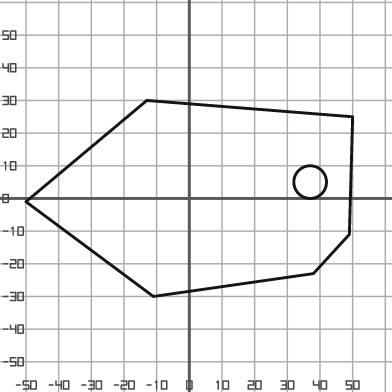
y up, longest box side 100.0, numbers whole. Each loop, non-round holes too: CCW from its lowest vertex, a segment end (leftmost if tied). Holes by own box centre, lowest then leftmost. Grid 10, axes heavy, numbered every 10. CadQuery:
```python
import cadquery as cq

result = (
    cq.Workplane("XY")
    .moveTo(-11.0, -30.0)
    .lineTo(38.0, -23.0)
    .lineTo(49.0, -11.0)
    .lineTo(50.0, 25.0)
    .lineTo(-13.0, 30.0)
    .lineTo(-50.0, -1.0)
    .close()
    .moveTo(37.0, 5.0)
    .circle(5.0)
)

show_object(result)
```